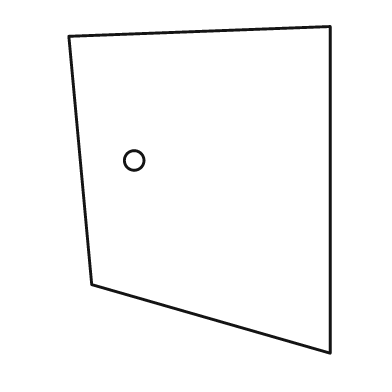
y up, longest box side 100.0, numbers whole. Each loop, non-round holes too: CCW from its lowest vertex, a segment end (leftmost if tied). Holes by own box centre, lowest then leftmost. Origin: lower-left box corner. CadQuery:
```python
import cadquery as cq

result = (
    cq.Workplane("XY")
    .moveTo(80.0, 0.0)
    .lineTo(80.0, 100.0)
    .lineTo(0.0, 97.0)
    .lineTo(7.0, 21.0)
    .close()
    .moveTo(20.0, 59.0)
    .circle(3.0)
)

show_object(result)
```